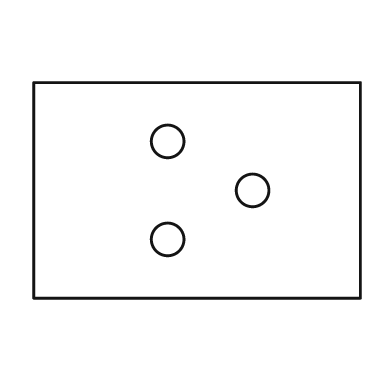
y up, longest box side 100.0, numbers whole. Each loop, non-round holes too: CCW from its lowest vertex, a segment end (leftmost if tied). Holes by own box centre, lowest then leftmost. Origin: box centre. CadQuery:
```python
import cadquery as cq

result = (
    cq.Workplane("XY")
    .moveTo(-50.0, -33.0)
    .lineTo(50.0, -33.0)
    .lineTo(50.0, 33.0)
    .lineTo(-50.0, 33.0)
    .close()
    .moveTo(-9.0, -15.0)
    .circle(5.0)
    .moveTo(17.0, 0.0)
    .circle(5.0)
    .moveTo(-9.0, 15.0)
    .circle(5.0)
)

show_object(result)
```